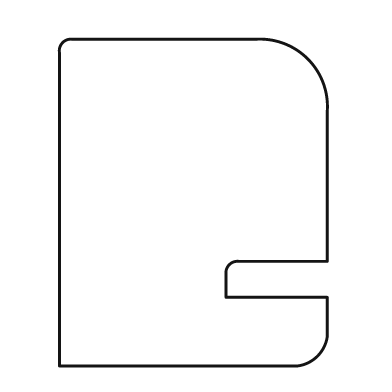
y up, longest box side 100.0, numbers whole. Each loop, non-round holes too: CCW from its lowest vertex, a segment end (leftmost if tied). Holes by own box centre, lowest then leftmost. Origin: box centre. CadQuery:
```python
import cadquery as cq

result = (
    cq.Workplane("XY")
    .moveTo(-41.0, -50.0)
    .lineTo(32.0, -50.0)
    .threePointArc((38.0, -47.0), (41.0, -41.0))
    .lineTo(41.0, -29.0)
    .lineTo(10.0, -29.0)
    .lineTo(10.0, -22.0)
    .threePointArc((11.0, -19.0), (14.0, -18.0))
    .lineTo(41.0, -18.0)
    .lineTo(41.0, 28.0)
    .threePointArc((35.0, 44.0), (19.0, 50.0))
    .lineTo(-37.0, 50.0)
    .threePointArc((-40.0, 49.0), (-41.0, 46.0))
    .close()
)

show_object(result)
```